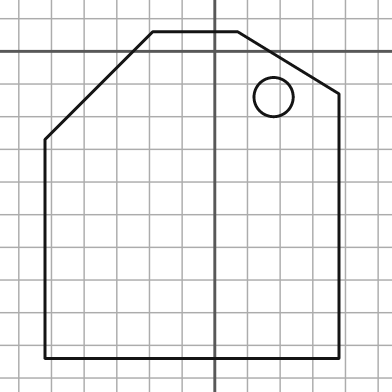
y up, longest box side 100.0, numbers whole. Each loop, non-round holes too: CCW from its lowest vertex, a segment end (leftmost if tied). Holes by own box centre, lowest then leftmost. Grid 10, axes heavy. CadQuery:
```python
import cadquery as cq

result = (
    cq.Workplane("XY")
    .moveTo(-52.0, -94.0)
    .lineTo(38.0, -94.0)
    .lineTo(38.0, -13.0)
    .lineTo(7.0, 6.0)
    .lineTo(-19.0, 6.0)
    .lineTo(-52.0, -27.0)
    .close()
    .moveTo(18.0, -14.0)
    .circle(6.0)
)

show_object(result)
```